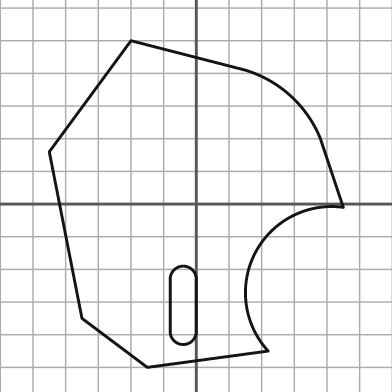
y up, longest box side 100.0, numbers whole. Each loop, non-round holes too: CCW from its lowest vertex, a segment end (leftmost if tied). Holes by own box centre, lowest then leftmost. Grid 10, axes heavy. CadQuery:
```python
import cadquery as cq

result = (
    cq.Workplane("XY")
    .moveTo(-15.0, -50.0)
    .lineTo(22.0, -45.0)
    .threePointArc((18.0, -15.0), (45.0, -1.0))
    .lineTo(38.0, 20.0)
    .threePointArc((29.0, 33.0), (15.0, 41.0))
    .lineTo(-20.0, 50.0)
    .lineTo(-45.0, 16.0)
    .lineTo(-35.0, -35.0)
    .close()
    .moveTo(-8.0, -39.0)
    .threePointArc((-4.0, -43.0), (0.0, -39.0))
    .lineTo(0.0, -23.0)
    .threePointArc((-4.0, -19.0), (-8.0, -23.0))
    .close()
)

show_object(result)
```